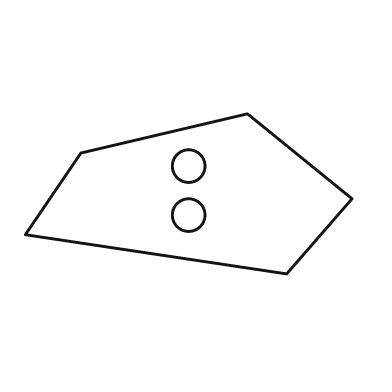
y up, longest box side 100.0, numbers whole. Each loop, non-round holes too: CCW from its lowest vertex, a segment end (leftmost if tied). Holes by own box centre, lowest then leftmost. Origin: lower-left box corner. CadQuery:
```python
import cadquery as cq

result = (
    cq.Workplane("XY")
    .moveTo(80.0, 0.0)
    .lineTo(100.0, 23.0)
    .lineTo(68.0, 49.0)
    .lineTo(17.0, 37.0)
    .lineTo(0.0, 12.0)
    .close()
    .moveTo(50.0, 18.0)
    .circle(5.0)
    .moveTo(50.0, 33.0)
    .circle(5.0)
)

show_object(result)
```